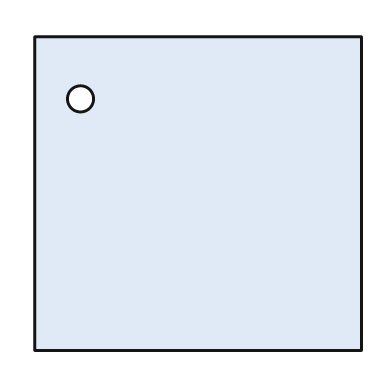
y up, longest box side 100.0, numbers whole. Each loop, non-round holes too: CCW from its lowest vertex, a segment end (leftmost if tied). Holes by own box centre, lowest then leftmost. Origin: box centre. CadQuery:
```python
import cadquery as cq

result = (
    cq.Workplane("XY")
    .moveTo(-50.0, -48.0)
    .lineTo(50.0, -48.0)
    .lineTo(50.0, 48.0)
    .lineTo(-50.0, 48.0)
    .close()
    .moveTo(-36.0, 29.0)
    .circle(4.0)
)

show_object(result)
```